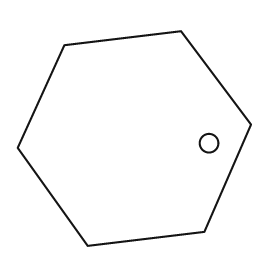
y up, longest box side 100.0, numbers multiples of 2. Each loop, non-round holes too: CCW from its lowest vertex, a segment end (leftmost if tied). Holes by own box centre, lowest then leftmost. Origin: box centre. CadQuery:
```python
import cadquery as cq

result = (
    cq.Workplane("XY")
    .moveTo(-20.0, -46.0)
    .lineTo(30.0, -40.0)
    .lineTo(50.0, 6.0)
    .lineTo(20.0, 46.0)
    .lineTo(-30.0, 40.0)
    .lineTo(-50.0, -4.0)
    .close()
    .moveTo(32.0, -2.0)
    .circle(4.0)
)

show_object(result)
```